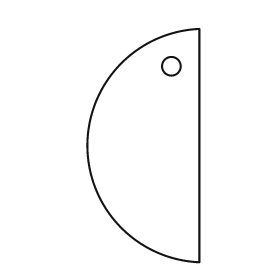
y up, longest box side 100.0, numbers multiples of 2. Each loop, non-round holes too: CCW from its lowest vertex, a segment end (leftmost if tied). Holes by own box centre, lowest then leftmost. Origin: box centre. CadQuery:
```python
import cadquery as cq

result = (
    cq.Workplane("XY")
    .moveTo(24.0, -50.0)
    .lineTo(24.0, 50.0)
    .threePointArc((-24.0, 0.0), (24.0, -50.0))
    .close()
    .moveTo(12.0, 34.0)
    .circle(4.0)
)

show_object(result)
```